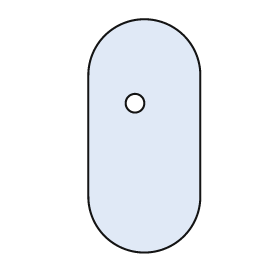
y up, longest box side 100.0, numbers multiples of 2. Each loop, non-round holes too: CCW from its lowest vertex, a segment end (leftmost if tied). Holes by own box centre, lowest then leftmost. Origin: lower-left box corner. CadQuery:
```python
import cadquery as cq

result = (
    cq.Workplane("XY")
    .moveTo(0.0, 24.0)
    .threePointArc((24.0, 0.0), (48.0, 24.0))
    .lineTo(48.0, 76.0)
    .threePointArc((24.0, 100.0), (0.0, 76.0))
    .close()
    .moveTo(20.0, 64.0)
    .circle(4.0)
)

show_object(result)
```